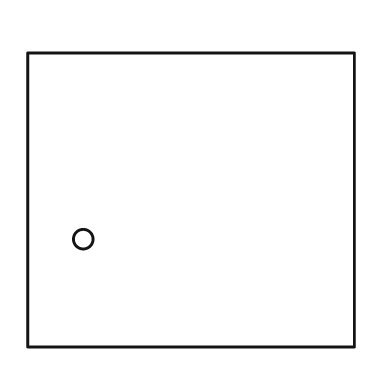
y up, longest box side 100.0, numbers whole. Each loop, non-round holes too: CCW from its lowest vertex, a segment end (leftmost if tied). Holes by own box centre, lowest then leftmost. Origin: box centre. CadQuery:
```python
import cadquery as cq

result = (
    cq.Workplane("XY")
    .moveTo(-50.0, -45.0)
    .lineTo(50.0, -45.0)
    .lineTo(50.0, 45.0)
    .lineTo(-50.0, 45.0)
    .close()
    .moveTo(-33.0, -12.0)
    .circle(3.0)
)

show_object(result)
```